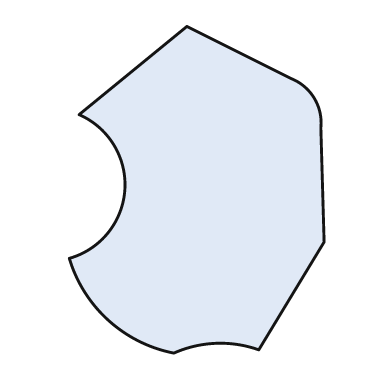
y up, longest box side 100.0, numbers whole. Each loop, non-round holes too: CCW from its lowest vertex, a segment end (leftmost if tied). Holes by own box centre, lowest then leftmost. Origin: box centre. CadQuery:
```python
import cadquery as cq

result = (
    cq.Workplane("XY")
    .moveTo(-7.0, -50.0)
    .threePointArc((6.0, -47.0), (19.0, -49.0))
    .lineTo(39.0, -16.0)
    .lineTo(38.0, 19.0)
    .threePointArc((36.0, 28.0), (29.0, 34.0))
    .lineTo(-3.0, 50.0)
    .lineTo(-36.0, 23.0)
    .threePointArc((-22.0, 0.0), (-39.0, -21.0))
    .threePointArc((-27.0, -40.0), (-7.0, -50.0))
    .close()
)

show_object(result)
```